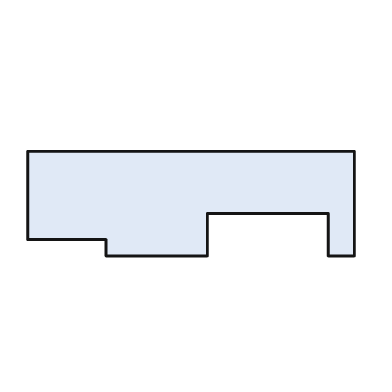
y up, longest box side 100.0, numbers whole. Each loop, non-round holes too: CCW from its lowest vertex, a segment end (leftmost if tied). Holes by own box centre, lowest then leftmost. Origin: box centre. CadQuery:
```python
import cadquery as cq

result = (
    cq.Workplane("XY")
    .moveTo(-26.0, -16.0)
    .lineTo(5.0, -16.0)
    .lineTo(5.0, -3.0)
    .lineTo(42.0, -3.0)
    .lineTo(42.0, -16.0)
    .lineTo(50.0, -16.0)
    .lineTo(50.0, 16.0)
    .lineTo(-50.0, 16.0)
    .lineTo(-50.0, -11.0)
    .lineTo(-26.0, -11.0)
    .close()
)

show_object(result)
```